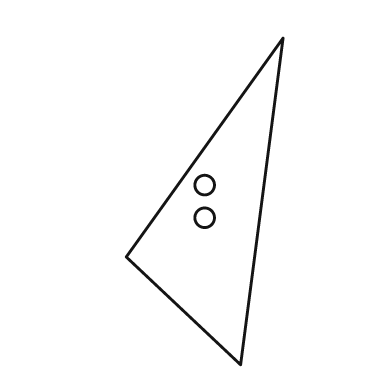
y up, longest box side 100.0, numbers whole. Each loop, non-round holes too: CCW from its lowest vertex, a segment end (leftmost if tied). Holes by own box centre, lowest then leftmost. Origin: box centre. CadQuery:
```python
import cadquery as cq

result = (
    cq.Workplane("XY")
    .moveTo(11.0, -50.0)
    .lineTo(24.0, 50.0)
    .lineTo(-24.0, -17.0)
    .close()
    .moveTo(0.0, -5.0)
    .circle(3.0)
    .moveTo(0.0, 5.0)
    .circle(3.0)
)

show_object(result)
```